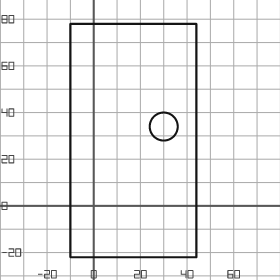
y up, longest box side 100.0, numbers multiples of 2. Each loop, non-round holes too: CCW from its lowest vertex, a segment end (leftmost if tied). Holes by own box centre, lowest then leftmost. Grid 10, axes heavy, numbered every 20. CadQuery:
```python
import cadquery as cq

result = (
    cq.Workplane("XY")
    .moveTo(-10.0, -22.0)
    .lineTo(44.0, -22.0)
    .lineTo(44.0, 78.0)
    .lineTo(-10.0, 78.0)
    .close()
    .moveTo(30.0, 34.0)
    .circle(6.0)
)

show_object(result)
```